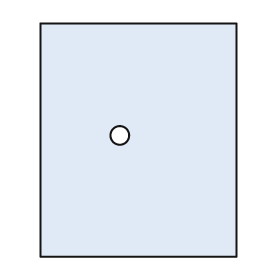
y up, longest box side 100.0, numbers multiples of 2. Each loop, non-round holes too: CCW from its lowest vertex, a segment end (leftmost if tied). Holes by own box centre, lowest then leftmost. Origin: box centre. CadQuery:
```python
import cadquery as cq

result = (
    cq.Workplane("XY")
    .moveTo(-42.0, -50.0)
    .lineTo(42.0, -50.0)
    .lineTo(42.0, 50.0)
    .lineTo(-42.0, 50.0)
    .close()
    .moveTo(-8.0, 2.0)
    .circle(4.0)
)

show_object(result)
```